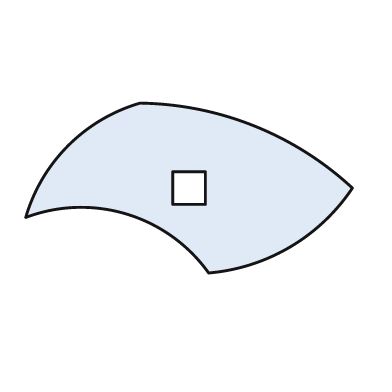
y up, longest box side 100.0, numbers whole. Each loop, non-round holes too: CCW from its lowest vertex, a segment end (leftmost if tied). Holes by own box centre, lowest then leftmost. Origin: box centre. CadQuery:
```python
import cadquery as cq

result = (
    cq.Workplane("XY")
    .moveTo(6.0, -26.0)
    .threePointArc((31.0, -18.0), (50.0, 0.0))
    .threePointArc((20.0, 19.0), (-15.0, 26.0))
    .threePointArc((-37.0, 13.0), (-50.0, -9.0))
    .threePointArc((-19.0, -8.0), (6.0, -26.0))
    .close()
    .moveTo(-5.0, -5.0)
    .lineTo(5.0, -5.0)
    .lineTo(5.0, 5.0)
    .lineTo(-5.0, 5.0)
    .close()
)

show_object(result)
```